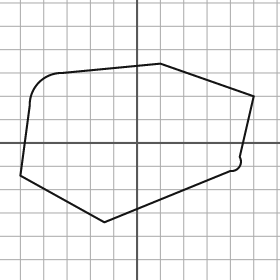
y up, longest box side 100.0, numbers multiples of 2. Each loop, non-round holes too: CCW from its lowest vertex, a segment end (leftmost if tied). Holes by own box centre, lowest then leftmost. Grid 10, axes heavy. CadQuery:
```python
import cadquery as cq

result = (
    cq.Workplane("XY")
    .moveTo(-14.0, -34.0)
    .lineTo(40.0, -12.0)
    .threePointArc((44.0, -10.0), (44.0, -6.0))
    .lineTo(50.0, 20.0)
    .lineTo(10.0, 34.0)
    .lineTo(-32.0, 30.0)
    .threePointArc((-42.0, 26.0), (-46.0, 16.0))
    .lineTo(-50.0, -14.0)
    .close()
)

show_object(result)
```